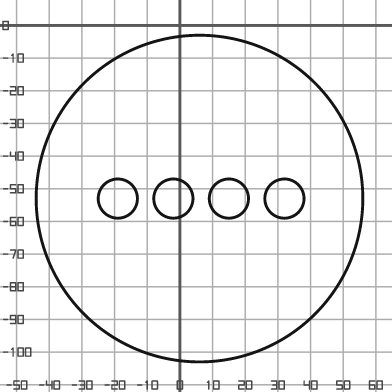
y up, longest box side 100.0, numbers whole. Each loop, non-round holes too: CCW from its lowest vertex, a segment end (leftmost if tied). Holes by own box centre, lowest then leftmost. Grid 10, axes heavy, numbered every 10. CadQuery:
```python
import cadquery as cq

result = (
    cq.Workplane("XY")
    .moveTo(6.0, -53.0)
    .circle(50.0)
    .moveTo(-19.0, -53.0)
    .circle(6.0)
    .moveTo(-2.0, -53.0)
    .circle(6.0)
    .moveTo(15.0, -53.0)
    .circle(6.0)
    .moveTo(32.0, -53.0)
    .circle(6.0)
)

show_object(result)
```